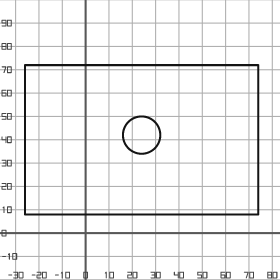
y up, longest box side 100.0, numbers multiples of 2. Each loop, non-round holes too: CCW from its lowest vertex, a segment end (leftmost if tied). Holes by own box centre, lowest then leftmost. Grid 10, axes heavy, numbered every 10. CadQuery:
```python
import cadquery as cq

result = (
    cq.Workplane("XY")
    .moveTo(-26.0, 8.0)
    .lineTo(74.0, 8.0)
    .lineTo(74.0, 72.0)
    .lineTo(-26.0, 72.0)
    .close()
    .moveTo(24.0, 42.0)
    .circle(8.0)
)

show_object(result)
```